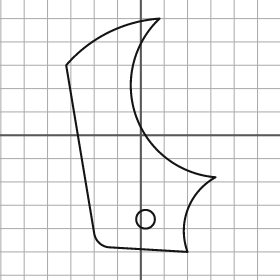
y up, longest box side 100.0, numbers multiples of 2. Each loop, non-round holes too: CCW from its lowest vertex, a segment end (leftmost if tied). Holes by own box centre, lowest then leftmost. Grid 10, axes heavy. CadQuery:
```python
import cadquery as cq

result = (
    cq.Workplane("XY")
    .moveTo(20.0, -50.0)
    .threePointArc((20.0, -32.0), (32.0, -18.0))
    .threePointArc((-2.0, 8.0), (8.0, 50.0))
    .threePointArc((-14.0, 44.0), (-32.0, 30.0))
    .lineTo(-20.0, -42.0)
    .threePointArc((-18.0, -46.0), (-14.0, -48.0))
    .close()
    .moveTo(2.0, -36.0)
    .circle(4.0)
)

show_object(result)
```